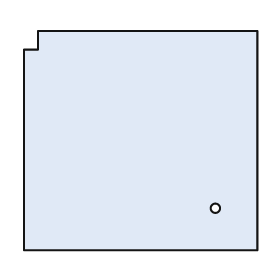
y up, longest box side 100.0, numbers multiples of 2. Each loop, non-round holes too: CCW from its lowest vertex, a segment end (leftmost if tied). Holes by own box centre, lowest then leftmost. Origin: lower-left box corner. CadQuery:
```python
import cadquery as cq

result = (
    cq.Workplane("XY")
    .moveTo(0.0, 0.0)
    .lineTo(100.0, 0.0)
    .lineTo(100.0, 94.0)
    .lineTo(6.0, 94.0)
    .lineTo(6.0, 86.0)
    .lineTo(0.0, 86.0)
    .close()
    .moveTo(82.0, 18.0)
    .circle(2.0)
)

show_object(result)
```